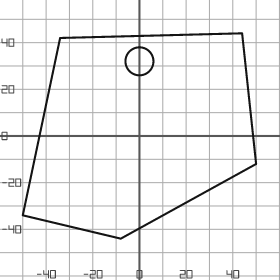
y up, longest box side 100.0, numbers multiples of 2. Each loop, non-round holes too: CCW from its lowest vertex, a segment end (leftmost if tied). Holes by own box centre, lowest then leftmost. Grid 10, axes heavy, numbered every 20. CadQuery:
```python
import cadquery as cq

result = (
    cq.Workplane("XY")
    .moveTo(-8.0, -44.0)
    .lineTo(50.0, -12.0)
    .lineTo(44.0, 44.0)
    .lineTo(-34.0, 42.0)
    .lineTo(-50.0, -34.0)
    .close()
    .moveTo(0.0, 32.0)
    .circle(6.0)
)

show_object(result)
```